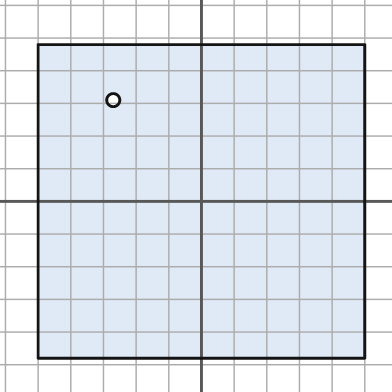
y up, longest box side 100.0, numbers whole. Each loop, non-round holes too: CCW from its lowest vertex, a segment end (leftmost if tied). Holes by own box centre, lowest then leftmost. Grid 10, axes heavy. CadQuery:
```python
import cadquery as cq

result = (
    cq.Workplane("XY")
    .moveTo(-50.0, -48.0)
    .lineTo(50.0, -48.0)
    .lineTo(50.0, 48.0)
    .lineTo(-50.0, 48.0)
    .close()
    .moveTo(-27.0, 31.0)
    .circle(2.0)
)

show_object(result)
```